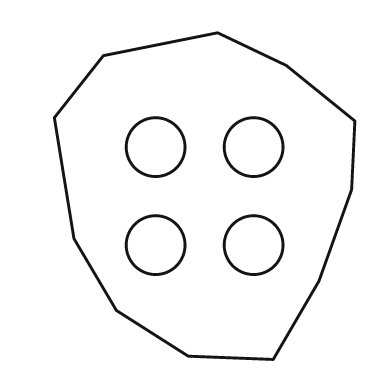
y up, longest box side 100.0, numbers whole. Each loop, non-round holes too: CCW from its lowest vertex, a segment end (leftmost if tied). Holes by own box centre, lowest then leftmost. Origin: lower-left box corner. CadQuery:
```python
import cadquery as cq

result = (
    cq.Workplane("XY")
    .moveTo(67.0, 0.0)
    .lineTo(81.0, 24.0)
    .lineTo(91.0, 52.0)
    .lineTo(92.0, 73.0)
    .lineTo(71.0, 90.0)
    .lineTo(50.0, 100.0)
    .lineTo(15.0, 93.0)
    .lineTo(0.0, 74.0)
    .lineTo(6.0, 37.0)
    .lineTo(19.0, 15.0)
    .lineTo(41.0, 1.0)
    .close()
    .moveTo(31.0, 35.0)
    .circle(9.0)
    .moveTo(61.0, 35.0)
    .circle(9.0)
    .moveTo(31.0, 65.0)
    .circle(9.0)
    .moveTo(61.0, 65.0)
    .circle(9.0)
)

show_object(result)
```